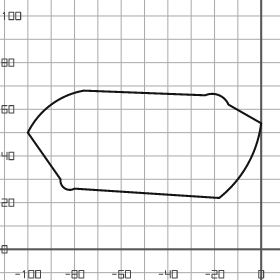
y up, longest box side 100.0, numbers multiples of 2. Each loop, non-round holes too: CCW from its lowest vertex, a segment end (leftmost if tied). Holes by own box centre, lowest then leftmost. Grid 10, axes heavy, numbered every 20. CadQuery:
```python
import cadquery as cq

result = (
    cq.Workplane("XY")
    .moveTo(-18.0, 22.0)
    .threePointArc((-6.0, 36.0), (0.0, 54.0))
    .lineTo(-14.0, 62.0)
    .threePointArc((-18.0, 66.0), (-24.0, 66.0))
    .lineTo(-76.0, 68.0)
    .threePointArc((-90.0, 62.0), (-100.0, 50.0))
    .lineTo(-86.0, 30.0)
    .threePointArc((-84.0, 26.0), (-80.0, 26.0))
    .close()
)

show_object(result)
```